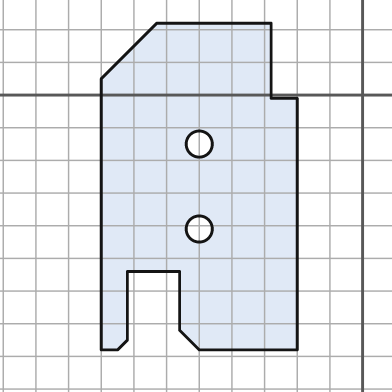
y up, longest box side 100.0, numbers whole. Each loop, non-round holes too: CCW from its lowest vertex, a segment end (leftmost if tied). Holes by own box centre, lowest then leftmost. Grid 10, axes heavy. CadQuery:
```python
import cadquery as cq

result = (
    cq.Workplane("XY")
    .moveTo(-80.0, -78.0)
    .lineTo(-75.0, -78.0)
    .lineTo(-72.0, -75.0)
    .lineTo(-72.0, -54.0)
    .lineTo(-56.0, -54.0)
    .lineTo(-56.0, -72.0)
    .lineTo(-50.0, -78.0)
    .lineTo(-20.0, -78.0)
    .lineTo(-20.0, -1.0)
    .lineTo(-28.0, -1.0)
    .lineTo(-28.0, 22.0)
    .lineTo(-63.0, 22.0)
    .lineTo(-80.0, 5.0)
    .close()
    .moveTo(-50.0, -41.0)
    .circle(4.0)
    .moveTo(-50.0, -15.0)
    .circle(4.0)
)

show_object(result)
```